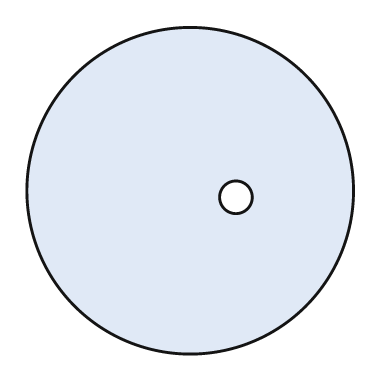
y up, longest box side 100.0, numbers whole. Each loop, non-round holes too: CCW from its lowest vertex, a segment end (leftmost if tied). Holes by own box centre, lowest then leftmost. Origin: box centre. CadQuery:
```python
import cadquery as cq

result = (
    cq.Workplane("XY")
    .moveTo(0.0, 0.0)
    .circle(50.0)
    .moveTo(14.0, -2.0)
    .circle(5.0)
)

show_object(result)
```